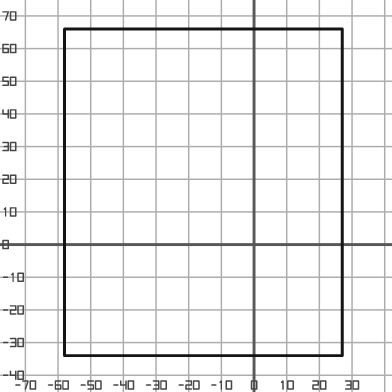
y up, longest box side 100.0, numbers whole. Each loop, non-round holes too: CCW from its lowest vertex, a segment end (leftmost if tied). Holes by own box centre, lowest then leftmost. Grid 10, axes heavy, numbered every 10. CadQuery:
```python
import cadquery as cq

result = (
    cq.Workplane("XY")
    .moveTo(-58.0, -34.0)
    .lineTo(27.0, -34.0)
    .lineTo(27.0, 66.0)
    .lineTo(-58.0, 66.0)
    .close()
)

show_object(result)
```